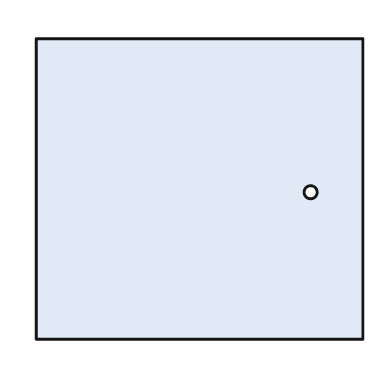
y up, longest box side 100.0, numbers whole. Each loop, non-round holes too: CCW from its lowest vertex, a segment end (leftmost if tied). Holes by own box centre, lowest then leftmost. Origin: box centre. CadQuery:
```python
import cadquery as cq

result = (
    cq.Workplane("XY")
    .moveTo(-50.0, -46.0)
    .lineTo(50.0, -46.0)
    .lineTo(50.0, 46.0)
    .lineTo(-50.0, 46.0)
    .close()
    .moveTo(34.0, -1.0)
    .circle(2.0)
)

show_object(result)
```